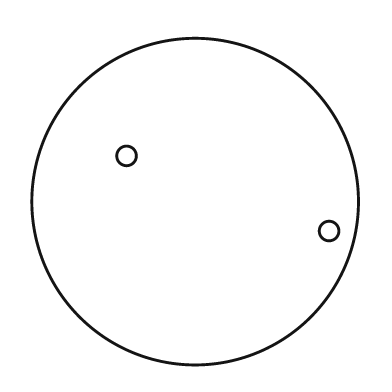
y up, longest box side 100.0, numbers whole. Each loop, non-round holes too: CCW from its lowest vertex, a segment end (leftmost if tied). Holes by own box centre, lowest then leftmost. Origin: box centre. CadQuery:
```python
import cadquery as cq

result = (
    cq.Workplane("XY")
    .moveTo(0.0, 0.0)
    .circle(50.0)
    .moveTo(41.0, -9.0)
    .circle(3.0)
    .moveTo(-21.0, 14.0)
    .circle(3.0)
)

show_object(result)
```